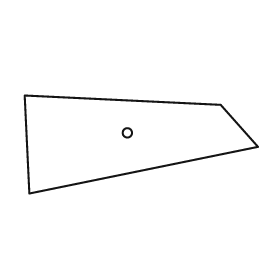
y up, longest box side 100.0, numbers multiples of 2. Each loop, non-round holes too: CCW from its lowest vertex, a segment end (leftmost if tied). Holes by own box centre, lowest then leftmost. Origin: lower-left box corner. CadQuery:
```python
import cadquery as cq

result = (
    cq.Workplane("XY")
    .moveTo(2.0, 0.0)
    .lineTo(100.0, 20.0)
    .lineTo(84.0, 38.0)
    .lineTo(0.0, 42.0)
    .close()
    .moveTo(44.0, 26.0)
    .circle(2.0)
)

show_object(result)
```